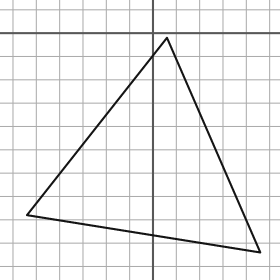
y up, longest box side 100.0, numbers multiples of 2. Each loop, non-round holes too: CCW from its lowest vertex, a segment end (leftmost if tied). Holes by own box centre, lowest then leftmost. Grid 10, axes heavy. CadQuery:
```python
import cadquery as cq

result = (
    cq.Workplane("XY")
    .moveTo(46.0, -94.0)
    .lineTo(6.0, -2.0)
    .lineTo(-54.0, -78.0)
    .close()
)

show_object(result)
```